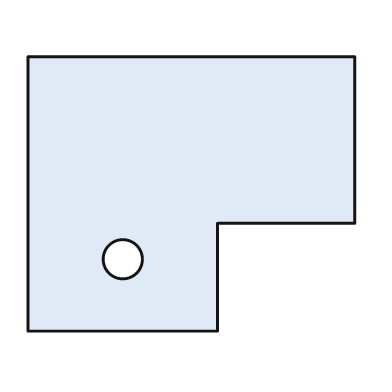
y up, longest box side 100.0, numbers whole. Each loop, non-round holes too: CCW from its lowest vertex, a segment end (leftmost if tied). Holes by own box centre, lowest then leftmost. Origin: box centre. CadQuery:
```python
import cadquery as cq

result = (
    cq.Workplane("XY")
    .moveTo(-50.0, -42.0)
    .lineTo(8.0, -42.0)
    .lineTo(8.0, -9.0)
    .lineTo(50.0, -9.0)
    .lineTo(50.0, 42.0)
    .lineTo(-50.0, 42.0)
    .close()
    .moveTo(-21.0, -20.0)
    .circle(6.0)
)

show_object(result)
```